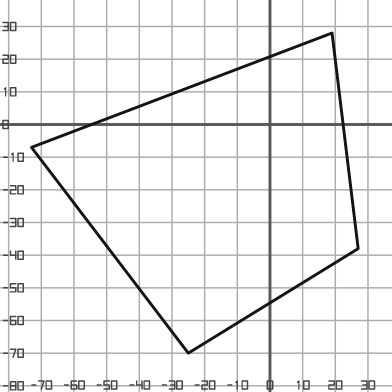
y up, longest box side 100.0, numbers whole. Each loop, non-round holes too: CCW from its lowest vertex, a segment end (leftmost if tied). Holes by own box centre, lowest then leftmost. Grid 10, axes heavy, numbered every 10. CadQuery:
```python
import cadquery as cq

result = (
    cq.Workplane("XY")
    .moveTo(-25.0, -70.0)
    .lineTo(27.0, -38.0)
    .lineTo(19.0, 28.0)
    .lineTo(-73.0, -7.0)
    .close()
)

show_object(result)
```